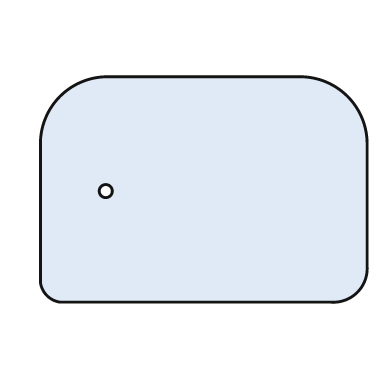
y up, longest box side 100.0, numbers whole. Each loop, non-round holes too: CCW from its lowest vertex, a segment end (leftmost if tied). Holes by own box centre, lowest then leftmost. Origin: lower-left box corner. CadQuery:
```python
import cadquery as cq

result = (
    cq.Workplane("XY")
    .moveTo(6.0, 0.0)
    .lineTo(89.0, 0.0)
    .threePointArc((97.0, 3.0), (100.0, 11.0))
    .lineTo(100.0, 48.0)
    .threePointArc((94.0, 63.0), (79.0, 69.0))
    .lineTo(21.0, 69.0)
    .threePointArc((6.0, 63.0), (0.0, 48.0))
    .lineTo(0.0, 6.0)
    .threePointArc((2.0, 2.0), (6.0, 0.0))
    .close()
    .moveTo(20.0, 34.0)
    .circle(2.0)
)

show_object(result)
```